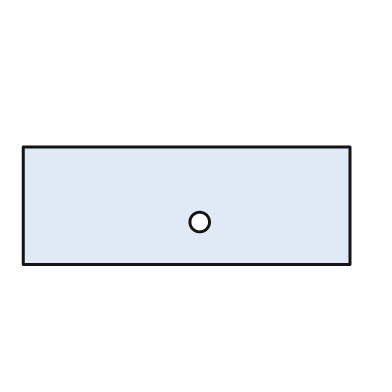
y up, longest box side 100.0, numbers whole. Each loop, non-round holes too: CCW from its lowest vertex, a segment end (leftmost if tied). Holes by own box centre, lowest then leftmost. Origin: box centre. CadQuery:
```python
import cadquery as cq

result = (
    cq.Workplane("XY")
    .moveTo(-50.0, -18.0)
    .lineTo(50.0, -18.0)
    .lineTo(50.0, 18.0)
    .lineTo(-50.0, 18.0)
    .close()
    .moveTo(4.0, -5.0)
    .circle(3.0)
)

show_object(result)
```